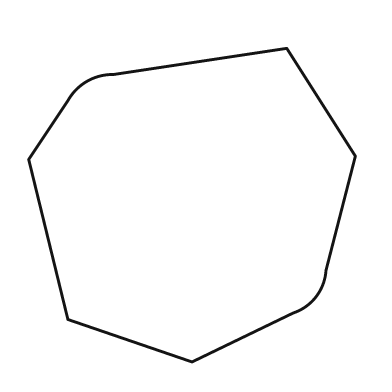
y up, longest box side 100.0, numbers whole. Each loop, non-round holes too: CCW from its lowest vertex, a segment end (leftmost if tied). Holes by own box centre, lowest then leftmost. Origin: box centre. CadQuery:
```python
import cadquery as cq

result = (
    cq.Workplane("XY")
    .moveTo(0.0, -48.0)
    .lineTo(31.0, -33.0)
    .threePointArc((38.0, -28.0), (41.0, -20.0))
    .lineTo(50.0, 15.0)
    .lineTo(29.0, 48.0)
    .lineTo(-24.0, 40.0)
    .threePointArc((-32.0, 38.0), (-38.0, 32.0))
    .lineTo(-50.0, 14.0)
    .lineTo(-38.0, -35.0)
    .close()
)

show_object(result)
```